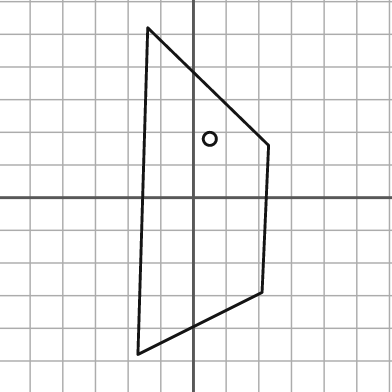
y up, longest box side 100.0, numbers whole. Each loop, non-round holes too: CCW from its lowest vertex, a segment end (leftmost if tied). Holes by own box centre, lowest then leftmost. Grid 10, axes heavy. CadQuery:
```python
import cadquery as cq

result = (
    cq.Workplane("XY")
    .moveTo(-17.0, -48.0)
    .lineTo(21.0, -29.0)
    .lineTo(23.0, 16.0)
    .lineTo(-14.0, 52.0)
    .close()
    .moveTo(5.0, 18.0)
    .circle(2.0)
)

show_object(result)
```